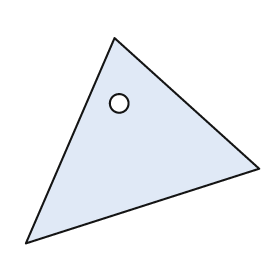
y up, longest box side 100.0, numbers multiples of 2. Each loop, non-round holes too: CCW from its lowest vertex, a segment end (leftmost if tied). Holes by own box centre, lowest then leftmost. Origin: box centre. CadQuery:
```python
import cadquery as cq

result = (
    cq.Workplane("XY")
    .moveTo(-50.0, -44.0)
    .lineTo(50.0, -12.0)
    .lineTo(-12.0, 44.0)
    .close()
    .moveTo(-10.0, 16.0)
    .circle(4.0)
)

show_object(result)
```